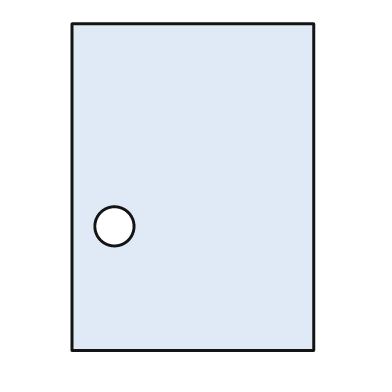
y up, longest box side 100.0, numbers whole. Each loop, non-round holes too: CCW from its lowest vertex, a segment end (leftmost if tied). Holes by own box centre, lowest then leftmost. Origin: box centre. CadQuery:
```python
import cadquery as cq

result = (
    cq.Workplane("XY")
    .moveTo(-37.0, -50.0)
    .lineTo(37.0, -50.0)
    .lineTo(37.0, 50.0)
    .lineTo(-37.0, 50.0)
    .close()
    .moveTo(-24.0, -12.0)
    .circle(6.0)
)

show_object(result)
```